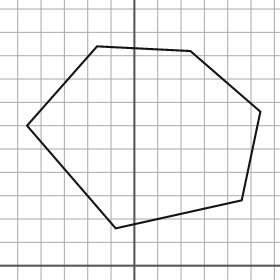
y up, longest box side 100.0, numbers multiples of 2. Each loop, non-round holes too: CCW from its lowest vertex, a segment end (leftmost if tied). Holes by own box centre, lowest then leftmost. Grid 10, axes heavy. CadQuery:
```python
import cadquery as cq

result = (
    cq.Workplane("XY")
    .moveTo(-8.0, 16.0)
    .lineTo(46.0, 28.0)
    .lineTo(54.0, 66.0)
    .lineTo(24.0, 92.0)
    .lineTo(-16.0, 94.0)
    .lineTo(-46.0, 60.0)
    .close()
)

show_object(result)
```